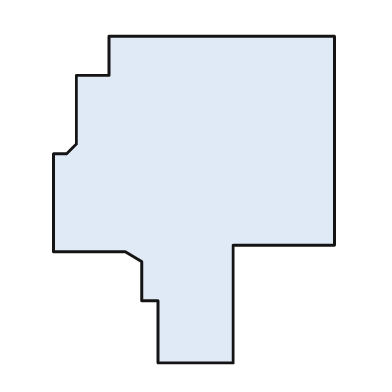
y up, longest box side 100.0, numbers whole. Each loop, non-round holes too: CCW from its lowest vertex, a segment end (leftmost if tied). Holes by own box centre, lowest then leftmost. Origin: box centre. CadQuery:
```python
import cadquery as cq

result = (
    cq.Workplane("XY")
    .moveTo(-11.0, -50.0)
    .lineTo(12.0, -50.0)
    .lineTo(12.0, -14.0)
    .lineTo(43.0, -14.0)
    .lineTo(43.0, 50.0)
    .lineTo(-26.0, 50.0)
    .lineTo(-26.0, 38.0)
    .lineTo(-36.0, 38.0)
    .lineTo(-36.0, 17.0)
    .lineTo(-39.0, 14.0)
    .lineTo(-43.0, 14.0)
    .lineTo(-43.0, -16.0)
    .lineTo(-21.0, -16.0)
    .lineTo(-16.0, -19.0)
    .lineTo(-16.0, -31.0)
    .lineTo(-11.0, -31.0)
    .close()
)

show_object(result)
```